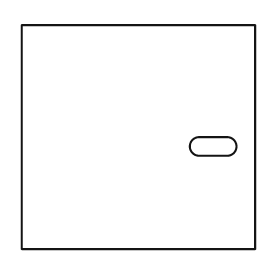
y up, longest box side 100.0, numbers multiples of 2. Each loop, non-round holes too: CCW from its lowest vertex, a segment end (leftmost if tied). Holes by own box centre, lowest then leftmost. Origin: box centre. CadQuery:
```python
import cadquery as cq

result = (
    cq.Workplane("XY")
    .moveTo(-50.0, -48.0)
    .lineTo(50.0, -48.0)
    .lineTo(50.0, 48.0)
    .lineTo(-50.0, 48.0)
    .close()
    .moveTo(26.0, -8.0)
    .lineTo(38.0, -8.0)
    .threePointArc((42.0, -4.0), (38.0, 0.0))
    .lineTo(26.0, 0.0)
    .threePointArc((22.0, -4.0), (26.0, -8.0))
    .close()
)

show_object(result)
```